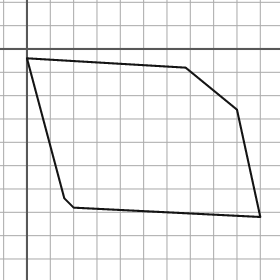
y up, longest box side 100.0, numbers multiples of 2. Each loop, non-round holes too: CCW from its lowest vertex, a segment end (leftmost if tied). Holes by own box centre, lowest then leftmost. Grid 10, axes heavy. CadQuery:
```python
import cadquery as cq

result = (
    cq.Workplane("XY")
    .moveTo(100.0, -72.0)
    .lineTo(90.0, -26.0)
    .lineTo(68.0, -8.0)
    .lineTo(0.0, -4.0)
    .lineTo(16.0, -64.0)
    .lineTo(20.0, -68.0)
    .close()
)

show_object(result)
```